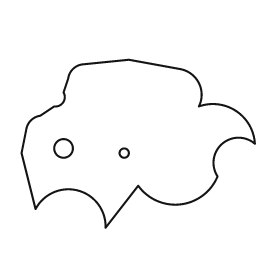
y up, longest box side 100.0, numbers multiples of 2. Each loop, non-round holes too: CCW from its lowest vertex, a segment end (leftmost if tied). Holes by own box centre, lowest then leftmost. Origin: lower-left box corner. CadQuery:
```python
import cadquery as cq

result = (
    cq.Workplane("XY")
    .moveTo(36.0, 0.0)
    .lineTo(50.0, 18.0)
    .threePointArc((68.0, 10.0), (84.0, 22.0))
    .threePointArc((86.0, 36.0), (100.0, 36.0))
    .threePointArc((92.0, 50.0), (76.0, 52.0))
    .threePointArc((76.0, 62.0), (68.0, 68.0))
    .lineTo(46.0, 72.0)
    .lineTo(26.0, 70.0)
    .threePointArc((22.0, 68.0), (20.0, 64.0))
    .lineTo(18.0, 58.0)
    .threePointArc((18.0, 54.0), (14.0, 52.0))
    .lineTo(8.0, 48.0)
    .threePointArc((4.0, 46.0), (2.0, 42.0))
    .lineTo(0.0, 32.0)
    .lineTo(6.0, 8.0)
    .threePointArc((24.0, 16.0), (36.0, 0.0))
    .close()
    .moveTo(44.0, 32.0)
    .circle(2.0)
    .moveTo(18.0, 34.0)
    .circle(4.0)
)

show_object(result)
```